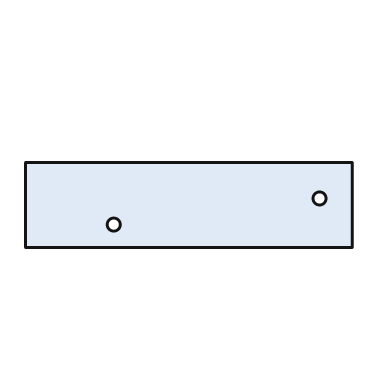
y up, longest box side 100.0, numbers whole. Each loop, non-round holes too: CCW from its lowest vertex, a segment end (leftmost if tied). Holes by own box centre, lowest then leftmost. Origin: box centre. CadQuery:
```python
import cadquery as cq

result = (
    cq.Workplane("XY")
    .moveTo(-50.0, -13.0)
    .lineTo(50.0, -13.0)
    .lineTo(50.0, 13.0)
    .lineTo(-50.0, 13.0)
    .close()
    .moveTo(-23.0, -6.0)
    .circle(2.0)
    .moveTo(40.0, 2.0)
    .circle(2.0)
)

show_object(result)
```